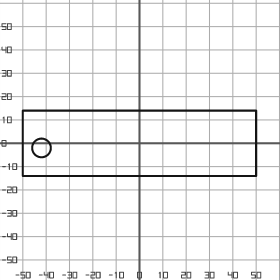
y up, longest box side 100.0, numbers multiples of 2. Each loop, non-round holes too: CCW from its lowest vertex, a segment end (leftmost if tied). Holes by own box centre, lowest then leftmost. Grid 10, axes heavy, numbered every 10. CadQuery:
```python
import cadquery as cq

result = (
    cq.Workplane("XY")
    .moveTo(-50.0, -14.0)
    .lineTo(50.0, -14.0)
    .lineTo(50.0, 14.0)
    .lineTo(-50.0, 14.0)
    .close()
    .moveTo(-42.0, -2.0)
    .circle(4.0)
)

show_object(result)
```